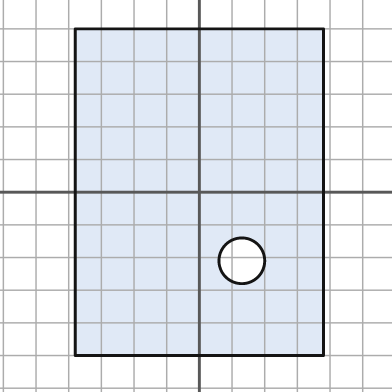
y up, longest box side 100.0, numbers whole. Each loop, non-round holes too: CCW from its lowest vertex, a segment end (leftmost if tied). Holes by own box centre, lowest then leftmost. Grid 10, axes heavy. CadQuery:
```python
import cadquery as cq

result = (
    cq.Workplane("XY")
    .moveTo(-38.0, -50.0)
    .lineTo(38.0, -50.0)
    .lineTo(38.0, 50.0)
    .lineTo(-38.0, 50.0)
    .close()
    .moveTo(13.0, -21.0)
    .circle(7.0)
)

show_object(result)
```